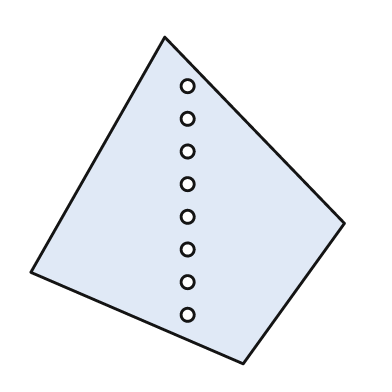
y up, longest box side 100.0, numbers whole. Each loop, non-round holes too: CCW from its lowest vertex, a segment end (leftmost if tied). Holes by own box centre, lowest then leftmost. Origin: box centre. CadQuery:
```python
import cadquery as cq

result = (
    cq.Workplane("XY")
    .moveTo(17.0, -50.0)
    .lineTo(48.0, -7.0)
    .lineTo(-7.0, 50.0)
    .lineTo(-48.0, -22.0)
    .close()
    .moveTo(0.0, -35.0)
    .circle(2.0)
    .moveTo(0.0, -25.0)
    .circle(2.0)
    .moveTo(0.0, -15.0)
    .circle(2.0)
    .moveTo(0.0, -5.0)
    .circle(2.0)
    .moveTo(0.0, 5.0)
    .circle(2.0)
    .moveTo(0.0, 15.0)
    .circle(2.0)
    .moveTo(0.0, 25.0)
    .circle(2.0)
    .moveTo(0.0, 35.0)
    .circle(2.0)
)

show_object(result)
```